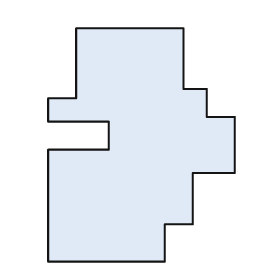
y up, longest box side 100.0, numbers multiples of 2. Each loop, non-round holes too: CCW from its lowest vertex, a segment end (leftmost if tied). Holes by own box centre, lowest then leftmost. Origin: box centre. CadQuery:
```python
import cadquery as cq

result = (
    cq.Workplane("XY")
    .moveTo(-40.0, -50.0)
    .lineTo(10.0, -50.0)
    .lineTo(10.0, -34.0)
    .lineTo(22.0, -34.0)
    .lineTo(22.0, -12.0)
    .lineTo(40.0, -12.0)
    .lineTo(40.0, 12.0)
    .lineTo(28.0, 12.0)
    .lineTo(28.0, 24.0)
    .lineTo(18.0, 24.0)
    .lineTo(18.0, 50.0)
    .lineTo(-28.0, 50.0)
    .lineTo(-28.0, 20.0)
    .lineTo(-40.0, 20.0)
    .lineTo(-40.0, 10.0)
    .lineTo(-14.0, 10.0)
    .lineTo(-14.0, -2.0)
    .lineTo(-40.0, -2.0)
    .close()
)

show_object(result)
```